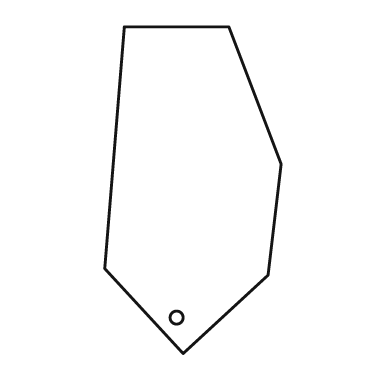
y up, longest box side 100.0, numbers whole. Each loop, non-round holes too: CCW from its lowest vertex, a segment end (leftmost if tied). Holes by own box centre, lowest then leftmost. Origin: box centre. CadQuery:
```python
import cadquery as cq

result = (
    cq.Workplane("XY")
    .moveTo(-3.0, -50.0)
    .lineTo(23.0, -26.0)
    .lineTo(27.0, 8.0)
    .lineTo(11.0, 50.0)
    .lineTo(-21.0, 50.0)
    .lineTo(-27.0, -24.0)
    .close()
    .moveTo(-5.0, -39.0)
    .circle(2.0)
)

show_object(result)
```